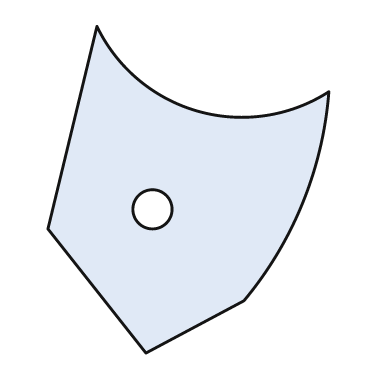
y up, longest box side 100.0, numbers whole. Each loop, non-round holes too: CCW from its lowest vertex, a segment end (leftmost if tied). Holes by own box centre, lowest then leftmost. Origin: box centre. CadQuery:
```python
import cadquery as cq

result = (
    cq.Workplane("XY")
    .moveTo(-13.0, -50.0)
    .lineTo(17.0, -34.0)
    .threePointArc((35.0, -4.0), (43.0, 30.0))
    .threePointArc((3.0, 24.0), (-28.0, 50.0))
    .lineTo(-43.0, -12.0)
    .close()
    .moveTo(-11.0, -6.0)
    .circle(6.0)
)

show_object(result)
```